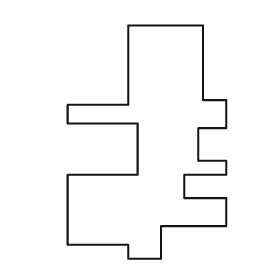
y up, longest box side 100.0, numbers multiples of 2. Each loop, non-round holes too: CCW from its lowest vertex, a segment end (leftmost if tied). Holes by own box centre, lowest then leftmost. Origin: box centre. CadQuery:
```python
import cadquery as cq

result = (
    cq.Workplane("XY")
    .moveTo(-8.0, -50.0)
    .lineTo(6.0, -50.0)
    .lineTo(6.0, -36.0)
    .lineTo(34.0, -36.0)
    .lineTo(34.0, -24.0)
    .lineTo(16.0, -24.0)
    .lineTo(16.0, -14.0)
    .lineTo(34.0, -14.0)
    .lineTo(34.0, -8.0)
    .lineTo(22.0, -8.0)
    .lineTo(22.0, 6.0)
    .lineTo(34.0, 6.0)
    .lineTo(34.0, 18.0)
    .lineTo(24.0, 18.0)
    .lineTo(24.0, 50.0)
    .lineTo(-8.0, 50.0)
    .lineTo(-8.0, 16.0)
    .lineTo(-34.0, 16.0)
    .lineTo(-34.0, 8.0)
    .lineTo(-4.0, 8.0)
    .lineTo(-4.0, -14.0)
    .lineTo(-34.0, -14.0)
    .lineTo(-34.0, -44.0)
    .lineTo(-8.0, -44.0)
    .close()
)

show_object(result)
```